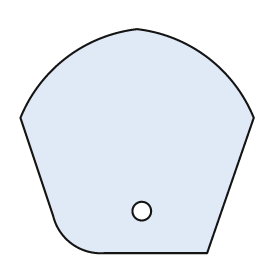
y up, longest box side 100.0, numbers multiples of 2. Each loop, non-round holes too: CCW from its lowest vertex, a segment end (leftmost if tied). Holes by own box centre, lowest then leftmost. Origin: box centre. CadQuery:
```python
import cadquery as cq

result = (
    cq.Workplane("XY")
    .moveTo(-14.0, -48.0)
    .lineTo(30.0, -48.0)
    .lineTo(50.0, 10.0)
    .threePointArc((30.0, 36.0), (0.0, 48.0))
    .threePointArc((-30.0, 36.0), (-50.0, 10.0))
    .lineTo(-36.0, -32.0)
    .threePointArc((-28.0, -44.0), (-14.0, -48.0))
    .close()
    .moveTo(2.0, -30.0)
    .circle(4.0)
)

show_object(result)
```